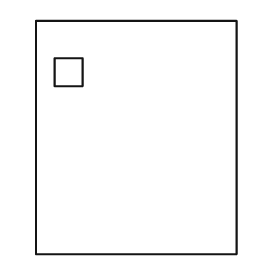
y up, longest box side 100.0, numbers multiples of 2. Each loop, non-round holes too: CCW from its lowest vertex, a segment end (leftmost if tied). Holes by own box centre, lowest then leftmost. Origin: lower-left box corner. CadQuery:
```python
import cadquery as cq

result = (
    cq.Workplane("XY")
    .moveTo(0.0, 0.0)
    .lineTo(86.0, 0.0)
    .lineTo(86.0, 100.0)
    .lineTo(0.0, 100.0)
    .close()
    .moveTo(8.0, 72.0)
    .lineTo(20.0, 72.0)
    .lineTo(20.0, 84.0)
    .lineTo(8.0, 84.0)
    .close()
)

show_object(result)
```